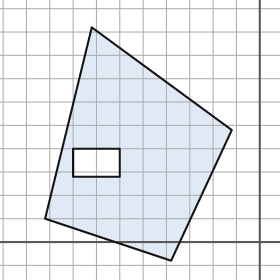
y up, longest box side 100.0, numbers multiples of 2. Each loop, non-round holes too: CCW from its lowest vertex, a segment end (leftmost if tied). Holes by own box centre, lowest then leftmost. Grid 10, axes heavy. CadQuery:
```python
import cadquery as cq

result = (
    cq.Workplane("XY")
    .moveTo(-38.0, -8.0)
    .lineTo(-12.0, 48.0)
    .lineTo(-72.0, 92.0)
    .lineTo(-92.0, 10.0)
    .close()
    .moveTo(-80.0, 28.0)
    .lineTo(-60.0, 28.0)
    .lineTo(-60.0, 40.0)
    .lineTo(-80.0, 40.0)
    .close()
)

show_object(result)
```